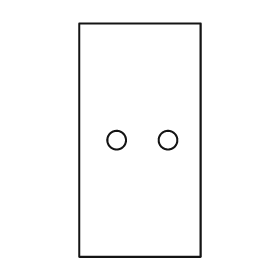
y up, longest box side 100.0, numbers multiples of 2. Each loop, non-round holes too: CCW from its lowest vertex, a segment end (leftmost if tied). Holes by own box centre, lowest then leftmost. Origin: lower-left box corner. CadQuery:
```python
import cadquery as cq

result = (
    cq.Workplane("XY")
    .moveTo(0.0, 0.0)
    .lineTo(52.0, 0.0)
    .lineTo(52.0, 100.0)
    .lineTo(0.0, 100.0)
    .close()
    .moveTo(16.0, 50.0)
    .circle(4.0)
    .moveTo(38.0, 50.0)
    .circle(4.0)
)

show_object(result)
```